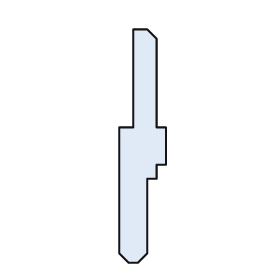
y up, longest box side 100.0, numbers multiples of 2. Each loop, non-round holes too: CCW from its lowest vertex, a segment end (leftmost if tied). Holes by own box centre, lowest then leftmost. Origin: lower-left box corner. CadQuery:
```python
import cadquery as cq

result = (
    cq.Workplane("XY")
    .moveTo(4.0, 0.0)
    .lineTo(8.0, 0.0)
    .lineTo(12.0, 4.0)
    .lineTo(12.0, 36.0)
    .lineTo(16.0, 36.0)
    .lineTo(16.0, 42.0)
    .lineTo(20.0, 42.0)
    .lineTo(20.0, 58.0)
    .lineTo(16.0, 58.0)
    .lineTo(16.0, 96.0)
    .lineTo(12.0, 100.0)
    .lineTo(6.0, 100.0)
    .lineTo(6.0, 58.0)
    .lineTo(0.0, 58.0)
    .lineTo(0.0, 4.0)
    .close()
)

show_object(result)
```